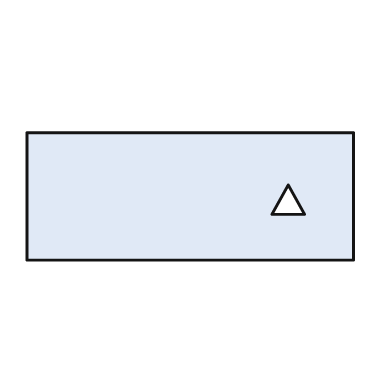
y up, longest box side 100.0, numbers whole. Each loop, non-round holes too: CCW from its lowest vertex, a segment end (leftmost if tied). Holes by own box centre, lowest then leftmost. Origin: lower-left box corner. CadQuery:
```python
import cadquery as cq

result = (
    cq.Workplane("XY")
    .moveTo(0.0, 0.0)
    .lineTo(100.0, 0.0)
    .lineTo(100.0, 39.0)
    .lineTo(0.0, 39.0)
    .close()
    .moveTo(75.0, 14.0)
    .lineTo(85.0, 14.0)
    .lineTo(80.0, 23.0)
    .close()
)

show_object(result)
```